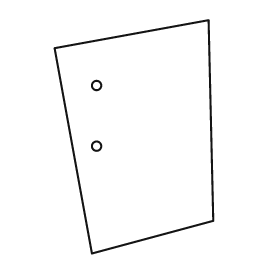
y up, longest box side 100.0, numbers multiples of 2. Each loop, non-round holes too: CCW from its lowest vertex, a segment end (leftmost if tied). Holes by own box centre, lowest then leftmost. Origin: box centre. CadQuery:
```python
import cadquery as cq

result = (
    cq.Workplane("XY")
    .moveTo(-18.0, -50.0)
    .lineTo(34.0, -36.0)
    .lineTo(32.0, 50.0)
    .lineTo(-34.0, 38.0)
    .close()
    .moveTo(-16.0, -4.0)
    .circle(2.0)
    .moveTo(-16.0, 22.0)
    .circle(2.0)
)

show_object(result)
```